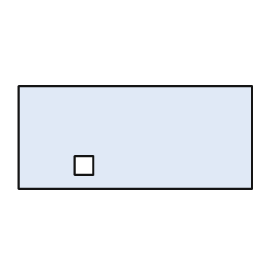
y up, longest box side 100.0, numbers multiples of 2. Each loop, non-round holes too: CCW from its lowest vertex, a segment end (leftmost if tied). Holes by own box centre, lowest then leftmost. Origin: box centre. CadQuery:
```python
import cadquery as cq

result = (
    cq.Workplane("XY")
    .moveTo(-50.0, -22.0)
    .lineTo(50.0, -22.0)
    .lineTo(50.0, 22.0)
    .lineTo(-50.0, 22.0)
    .close()
    .moveTo(-26.0, -16.0)
    .lineTo(-18.0, -16.0)
    .lineTo(-18.0, -8.0)
    .lineTo(-26.0, -8.0)
    .close()
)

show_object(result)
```